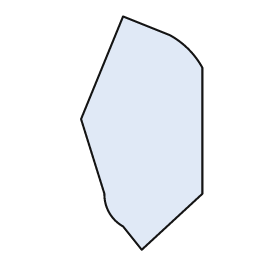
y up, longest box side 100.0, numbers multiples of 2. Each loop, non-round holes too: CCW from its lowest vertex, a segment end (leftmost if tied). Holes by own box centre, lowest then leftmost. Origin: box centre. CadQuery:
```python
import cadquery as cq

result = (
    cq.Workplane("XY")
    .moveTo(0.0, -50.0)
    .lineTo(26.0, -26.0)
    .lineTo(26.0, 28.0)
    .threePointArc((20.0, 36.0), (12.0, 42.0))
    .lineTo(-8.0, 50.0)
    .lineTo(-26.0, 6.0)
    .lineTo(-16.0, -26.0)
    .threePointArc((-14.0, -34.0), (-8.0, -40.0))
    .close()
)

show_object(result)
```